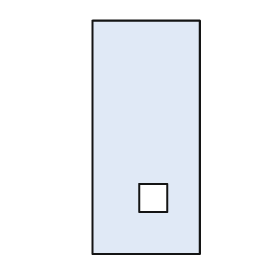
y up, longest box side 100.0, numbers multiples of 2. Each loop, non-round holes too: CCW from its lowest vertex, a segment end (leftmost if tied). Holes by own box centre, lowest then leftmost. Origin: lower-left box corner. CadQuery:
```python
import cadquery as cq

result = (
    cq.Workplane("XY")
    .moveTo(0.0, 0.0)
    .lineTo(46.0, 0.0)
    .lineTo(46.0, 100.0)
    .lineTo(0.0, 100.0)
    .close()
    .moveTo(20.0, 18.0)
    .lineTo(32.0, 18.0)
    .lineTo(32.0, 30.0)
    .lineTo(20.0, 30.0)
    .close()
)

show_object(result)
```